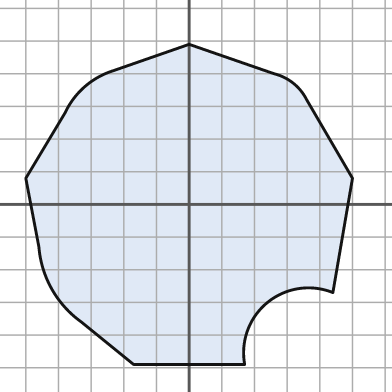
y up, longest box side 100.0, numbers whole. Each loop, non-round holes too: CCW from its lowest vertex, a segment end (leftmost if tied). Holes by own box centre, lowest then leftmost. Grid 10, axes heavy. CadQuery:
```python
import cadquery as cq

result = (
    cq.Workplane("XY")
    .moveTo(-17.0, -49.0)
    .lineTo(17.0, -49.0)
    .threePointArc((24.0, -30.0), (44.0, -27.0))
    .lineTo(50.0, 8.0)
    .lineTo(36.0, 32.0)
    .threePointArc((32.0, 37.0), (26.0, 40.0))
    .lineTo(0.0, 49.0)
    .lineTo(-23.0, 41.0)
    .threePointArc((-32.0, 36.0), (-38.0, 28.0))
    .lineTo(-50.0, 8.0)
    .lineTo(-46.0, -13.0)
    .threePointArc((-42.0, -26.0), (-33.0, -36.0))
    .close()
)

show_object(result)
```